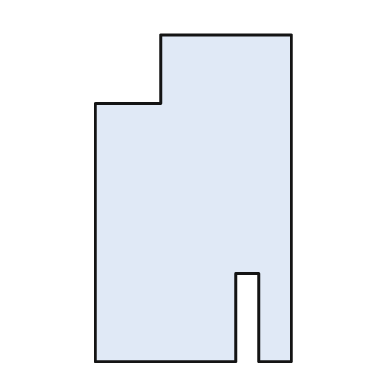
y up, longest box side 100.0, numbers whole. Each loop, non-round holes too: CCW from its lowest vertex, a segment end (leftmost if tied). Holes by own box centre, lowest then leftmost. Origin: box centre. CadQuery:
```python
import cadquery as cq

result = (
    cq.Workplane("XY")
    .moveTo(-30.0, -50.0)
    .lineTo(13.0, -50.0)
    .lineTo(13.0, -23.0)
    .lineTo(20.0, -23.0)
    .lineTo(20.0, -50.0)
    .lineTo(30.0, -50.0)
    .lineTo(30.0, 50.0)
    .lineTo(-10.0, 50.0)
    .lineTo(-10.0, 29.0)
    .lineTo(-30.0, 29.0)
    .close()
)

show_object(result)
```